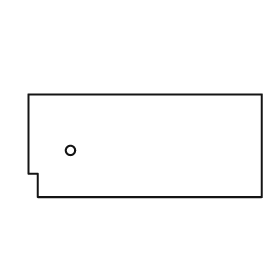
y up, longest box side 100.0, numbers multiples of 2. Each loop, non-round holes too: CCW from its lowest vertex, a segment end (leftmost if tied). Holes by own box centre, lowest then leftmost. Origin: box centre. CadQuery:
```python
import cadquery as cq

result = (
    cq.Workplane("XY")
    .moveTo(-46.0, -22.0)
    .lineTo(50.0, -22.0)
    .lineTo(50.0, 22.0)
    .lineTo(-50.0, 22.0)
    .lineTo(-50.0, -12.0)
    .lineTo(-46.0, -12.0)
    .close()
    .moveTo(-32.0, -2.0)
    .circle(2.0)
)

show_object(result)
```